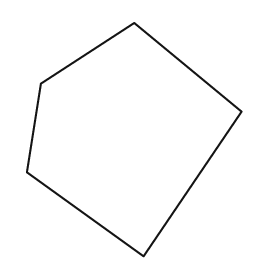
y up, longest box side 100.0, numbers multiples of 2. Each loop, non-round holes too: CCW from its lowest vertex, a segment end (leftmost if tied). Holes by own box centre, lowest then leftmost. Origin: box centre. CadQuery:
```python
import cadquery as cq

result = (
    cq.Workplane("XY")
    .moveTo(4.0, -50.0)
    .lineTo(46.0, 12.0)
    .lineTo(0.0, 50.0)
    .lineTo(-40.0, 24.0)
    .lineTo(-46.0, -14.0)
    .close()
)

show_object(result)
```